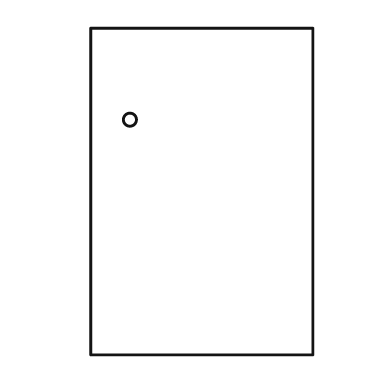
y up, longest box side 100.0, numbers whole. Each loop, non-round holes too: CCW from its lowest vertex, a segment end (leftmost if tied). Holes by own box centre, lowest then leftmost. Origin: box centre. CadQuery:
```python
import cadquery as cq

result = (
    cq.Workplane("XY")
    .moveTo(-34.0, -50.0)
    .lineTo(34.0, -50.0)
    .lineTo(34.0, 50.0)
    .lineTo(-34.0, 50.0)
    .close()
    .moveTo(-22.0, 22.0)
    .circle(2.0)
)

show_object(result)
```